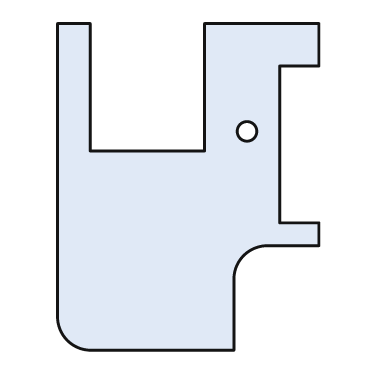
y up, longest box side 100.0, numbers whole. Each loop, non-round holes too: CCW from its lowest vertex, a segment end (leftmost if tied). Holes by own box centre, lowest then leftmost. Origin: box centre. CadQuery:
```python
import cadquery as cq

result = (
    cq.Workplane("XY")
    .moveTo(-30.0, -50.0)
    .lineTo(14.0, -50.0)
    .lineTo(14.0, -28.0)
    .threePointArc((17.0, -21.0), (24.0, -18.0))
    .lineTo(40.0, -18.0)
    .lineTo(40.0, -11.0)
    .lineTo(28.0, -11.0)
    .lineTo(28.0, 37.0)
    .lineTo(40.0, 37.0)
    .lineTo(40.0, 50.0)
    .lineTo(5.0, 50.0)
    .lineTo(5.0, 11.0)
    .lineTo(-30.0, 11.0)
    .lineTo(-30.0, 50.0)
    .lineTo(-40.0, 50.0)
    .lineTo(-40.0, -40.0)
    .threePointArc((-37.0, -47.0), (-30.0, -50.0))
    .close()
    .moveTo(18.0, 17.0)
    .circle(3.0)
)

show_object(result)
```